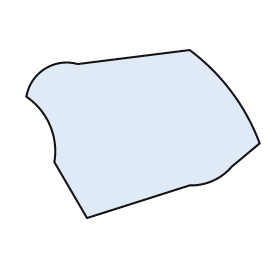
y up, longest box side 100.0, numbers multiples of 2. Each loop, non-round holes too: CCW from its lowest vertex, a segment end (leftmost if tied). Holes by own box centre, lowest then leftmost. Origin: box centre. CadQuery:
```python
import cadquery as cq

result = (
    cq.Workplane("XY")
    .moveTo(-24.0, -36.0)
    .lineTo(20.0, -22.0)
    .threePointArc((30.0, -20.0), (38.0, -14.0))
    .lineTo(50.0, -4.0)
    .threePointArc((38.0, 18.0), (20.0, 36.0))
    .lineTo(-28.0, 30.0)
    .threePointArc((-42.0, 28.0), (-50.0, 16.0))
    .threePointArc((-40.0, 4.0), (-38.0, -12.0))
    .close()
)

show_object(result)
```